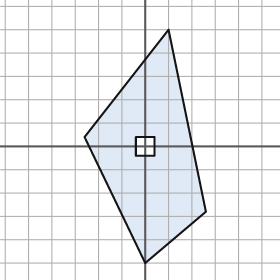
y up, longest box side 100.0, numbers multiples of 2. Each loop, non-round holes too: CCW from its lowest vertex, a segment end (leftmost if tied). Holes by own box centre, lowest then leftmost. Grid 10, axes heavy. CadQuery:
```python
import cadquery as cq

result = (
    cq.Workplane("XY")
    .moveTo(0.0, -50.0)
    .lineTo(26.0, -28.0)
    .lineTo(10.0, 50.0)
    .lineTo(-26.0, 4.0)
    .close()
    .moveTo(-4.0, -4.0)
    .lineTo(4.0, -4.0)
    .lineTo(4.0, 4.0)
    .lineTo(-4.0, 4.0)
    .close()
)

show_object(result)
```